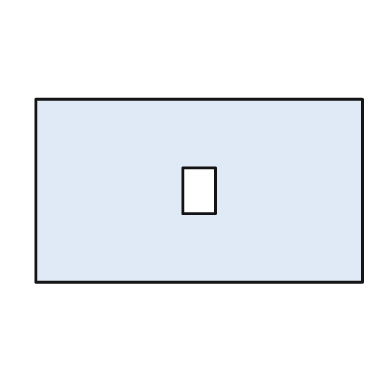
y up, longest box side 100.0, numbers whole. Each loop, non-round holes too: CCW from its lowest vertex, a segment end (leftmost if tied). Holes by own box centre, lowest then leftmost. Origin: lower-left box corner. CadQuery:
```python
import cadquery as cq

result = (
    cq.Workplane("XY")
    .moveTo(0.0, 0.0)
    .lineTo(100.0, 0.0)
    .lineTo(100.0, 56.0)
    .lineTo(0.0, 56.0)
    .close()
    .moveTo(45.0, 21.0)
    .lineTo(55.0, 21.0)
    .lineTo(55.0, 35.0)
    .lineTo(45.0, 35.0)
    .close()
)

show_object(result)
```